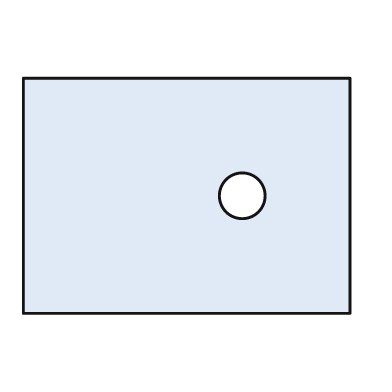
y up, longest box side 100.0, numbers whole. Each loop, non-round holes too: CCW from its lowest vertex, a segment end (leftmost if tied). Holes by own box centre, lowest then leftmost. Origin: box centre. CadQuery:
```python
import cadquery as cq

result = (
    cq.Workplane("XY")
    .moveTo(-50.0, -36.0)
    .lineTo(50.0, -36.0)
    .lineTo(50.0, 36.0)
    .lineTo(-50.0, 36.0)
    .close()
    .moveTo(17.0, 0.0)
    .circle(7.0)
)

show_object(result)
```